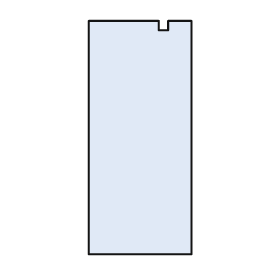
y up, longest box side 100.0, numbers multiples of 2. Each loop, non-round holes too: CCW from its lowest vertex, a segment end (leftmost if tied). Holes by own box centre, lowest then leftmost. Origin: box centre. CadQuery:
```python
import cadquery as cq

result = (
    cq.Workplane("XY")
    .moveTo(-22.0, -50.0)
    .lineTo(22.0, -50.0)
    .lineTo(22.0, 50.0)
    .lineTo(12.0, 50.0)
    .lineTo(12.0, 46.0)
    .lineTo(8.0, 46.0)
    .lineTo(8.0, 50.0)
    .lineTo(-22.0, 50.0)
    .close()
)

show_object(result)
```